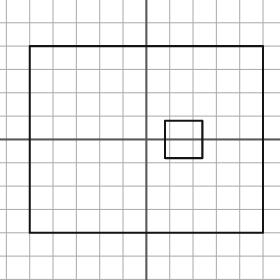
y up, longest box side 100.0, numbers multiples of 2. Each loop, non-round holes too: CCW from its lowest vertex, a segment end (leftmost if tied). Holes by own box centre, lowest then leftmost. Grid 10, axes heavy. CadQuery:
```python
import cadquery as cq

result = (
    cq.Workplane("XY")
    .moveTo(-50.0, -40.0)
    .lineTo(50.0, -40.0)
    .lineTo(50.0, 40.0)
    .lineTo(-50.0, 40.0)
    .close()
    .moveTo(8.0, -8.0)
    .lineTo(24.0, -8.0)
    .lineTo(24.0, 8.0)
    .lineTo(8.0, 8.0)
    .close()
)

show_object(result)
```